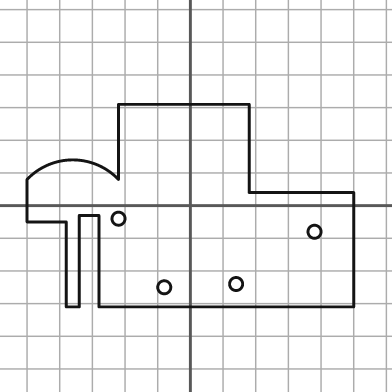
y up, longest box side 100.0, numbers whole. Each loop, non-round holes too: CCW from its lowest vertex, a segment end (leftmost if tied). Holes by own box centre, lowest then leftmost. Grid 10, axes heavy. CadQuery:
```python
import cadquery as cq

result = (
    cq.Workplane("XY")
    .moveTo(-38.0, -31.0)
    .lineTo(-34.0, -31.0)
    .lineTo(-34.0, -3.0)
    .lineTo(-28.0, -3.0)
    .lineTo(-28.0, -31.0)
    .lineTo(50.0, -31.0)
    .lineTo(50.0, 4.0)
    .lineTo(18.0, 4.0)
    .lineTo(18.0, 31.0)
    .lineTo(-22.0, 31.0)
    .lineTo(-22.0, 8.0)
    .threePointArc((-36.0, 14.0), (-50.0, 8.0))
    .lineTo(-50.0, -5.0)
    .lineTo(-38.0, -5.0)
    .close()
    .moveTo(-8.0, -25.0)
    .circle(2.0)
    .moveTo(14.0, -24.0)
    .circle(2.0)
    .moveTo(38.0, -8.0)
    .circle(2.0)
    .moveTo(-22.0, -4.0)
    .circle(2.0)
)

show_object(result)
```